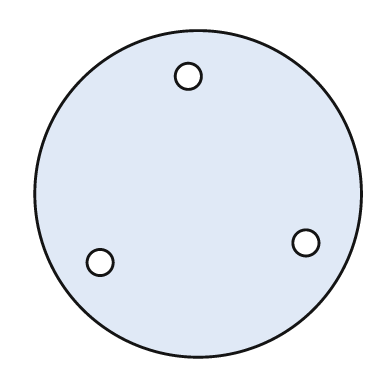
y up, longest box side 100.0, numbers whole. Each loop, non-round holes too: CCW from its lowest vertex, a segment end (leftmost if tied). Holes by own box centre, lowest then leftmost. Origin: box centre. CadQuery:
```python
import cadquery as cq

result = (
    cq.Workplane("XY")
    .moveTo(0.0, 0.0)
    .circle(50.0)
    .moveTo(-30.0, -21.0)
    .circle(4.0)
    .moveTo(33.0, -15.0)
    .circle(4.0)
    .moveTo(-3.0, 36.0)
    .circle(4.0)
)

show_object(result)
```